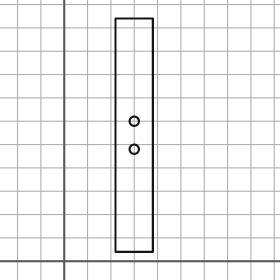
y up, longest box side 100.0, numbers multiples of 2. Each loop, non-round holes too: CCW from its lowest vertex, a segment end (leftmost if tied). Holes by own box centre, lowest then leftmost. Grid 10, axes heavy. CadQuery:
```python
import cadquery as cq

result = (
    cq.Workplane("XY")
    .moveTo(22.0, 4.0)
    .lineTo(38.0, 4.0)
    .lineTo(38.0, 104.0)
    .lineTo(22.0, 104.0)
    .close()
    .moveTo(30.0, 48.0)
    .circle(2.0)
    .moveTo(30.0, 60.0)
    .circle(2.0)
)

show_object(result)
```